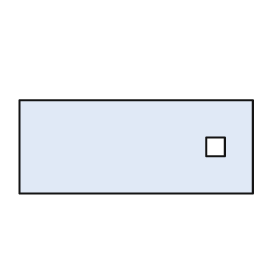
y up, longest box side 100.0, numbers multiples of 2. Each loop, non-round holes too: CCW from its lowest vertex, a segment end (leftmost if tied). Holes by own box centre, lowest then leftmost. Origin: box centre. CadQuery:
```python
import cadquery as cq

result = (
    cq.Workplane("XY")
    .moveTo(-50.0, -20.0)
    .lineTo(50.0, -20.0)
    .lineTo(50.0, 20.0)
    .lineTo(-50.0, 20.0)
    .close()
    .moveTo(30.0, -4.0)
    .lineTo(38.0, -4.0)
    .lineTo(38.0, 4.0)
    .lineTo(30.0, 4.0)
    .close()
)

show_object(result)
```